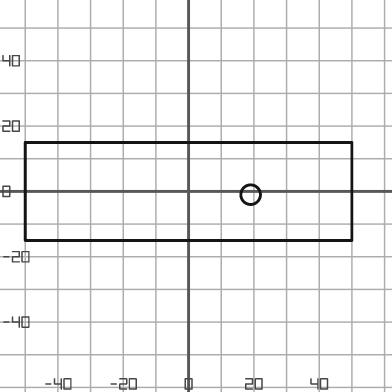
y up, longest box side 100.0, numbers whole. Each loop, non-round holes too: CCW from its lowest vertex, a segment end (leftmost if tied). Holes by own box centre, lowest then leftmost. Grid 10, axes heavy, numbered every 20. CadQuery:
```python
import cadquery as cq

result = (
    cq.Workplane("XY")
    .moveTo(-50.0, -15.0)
    .lineTo(50.0, -15.0)
    .lineTo(50.0, 15.0)
    .lineTo(-50.0, 15.0)
    .close()
    .moveTo(19.0, -1.0)
    .circle(3.0)
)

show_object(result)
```